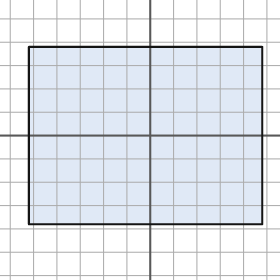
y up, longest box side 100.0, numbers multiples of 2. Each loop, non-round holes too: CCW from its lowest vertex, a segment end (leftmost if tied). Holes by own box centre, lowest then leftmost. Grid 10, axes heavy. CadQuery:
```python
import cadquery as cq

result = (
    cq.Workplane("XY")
    .moveTo(-52.0, -38.0)
    .lineTo(48.0, -38.0)
    .lineTo(48.0, 38.0)
    .lineTo(-52.0, 38.0)
    .close()
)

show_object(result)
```